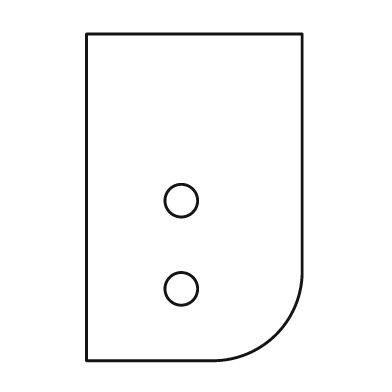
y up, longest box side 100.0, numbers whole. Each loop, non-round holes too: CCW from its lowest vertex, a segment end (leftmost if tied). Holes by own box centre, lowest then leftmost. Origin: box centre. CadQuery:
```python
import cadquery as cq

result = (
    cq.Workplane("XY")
    .moveTo(-33.0, -50.0)
    .lineTo(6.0, -50.0)
    .threePointArc((25.0, -42.0), (33.0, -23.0))
    .lineTo(33.0, 50.0)
    .lineTo(-33.0, 50.0)
    .close()
    .moveTo(-4.0, -28.0)
    .circle(5.0)
    .moveTo(-4.0, -1.0)
    .circle(5.0)
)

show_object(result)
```